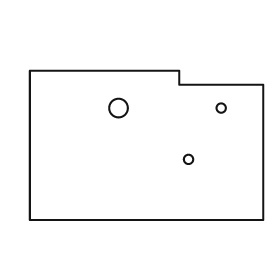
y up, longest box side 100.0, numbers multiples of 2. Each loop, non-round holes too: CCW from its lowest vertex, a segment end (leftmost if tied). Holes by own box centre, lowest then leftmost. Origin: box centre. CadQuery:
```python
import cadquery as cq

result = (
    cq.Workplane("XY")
    .moveTo(-50.0, -32.0)
    .lineTo(50.0, -32.0)
    .lineTo(50.0, 26.0)
    .lineTo(14.0, 26.0)
    .lineTo(14.0, 32.0)
    .lineTo(-50.0, 32.0)
    .close()
    .moveTo(18.0, -6.0)
    .circle(2.0)
    .moveTo(-12.0, 16.0)
    .circle(4.0)
    .moveTo(32.0, 16.0)
    .circle(2.0)
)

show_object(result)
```